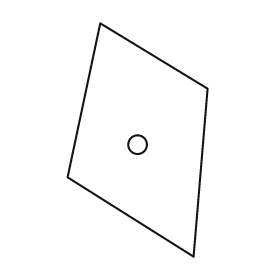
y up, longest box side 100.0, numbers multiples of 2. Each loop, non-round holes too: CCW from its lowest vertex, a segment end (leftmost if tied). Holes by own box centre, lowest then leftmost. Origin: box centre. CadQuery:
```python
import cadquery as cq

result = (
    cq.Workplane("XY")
    .moveTo(24.0, -50.0)
    .lineTo(30.0, 22.0)
    .lineTo(-16.0, 50.0)
    .lineTo(-30.0, -16.0)
    .close()
    .moveTo(0.0, -2.0)
    .circle(4.0)
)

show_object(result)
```